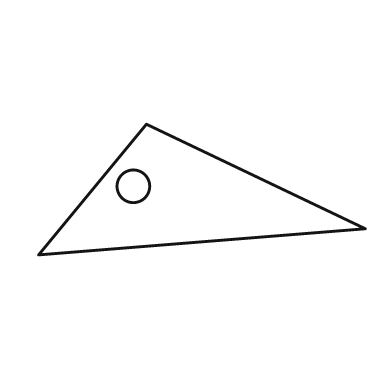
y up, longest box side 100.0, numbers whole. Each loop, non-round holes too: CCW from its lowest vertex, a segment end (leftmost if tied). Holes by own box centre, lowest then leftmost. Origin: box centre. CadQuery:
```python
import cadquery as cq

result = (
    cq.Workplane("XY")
    .moveTo(-50.0, -20.0)
    .lineTo(50.0, -12.0)
    .lineTo(-17.0, 20.0)
    .close()
    .moveTo(-21.0, 1.0)
    .circle(5.0)
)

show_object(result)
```